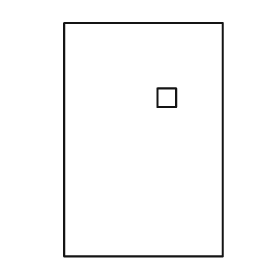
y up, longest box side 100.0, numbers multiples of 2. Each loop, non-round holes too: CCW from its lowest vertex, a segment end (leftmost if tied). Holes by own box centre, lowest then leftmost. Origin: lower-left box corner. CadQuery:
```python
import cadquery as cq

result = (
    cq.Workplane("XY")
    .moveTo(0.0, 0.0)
    .lineTo(68.0, 0.0)
    .lineTo(68.0, 100.0)
    .lineTo(0.0, 100.0)
    .close()
    .moveTo(40.0, 64.0)
    .lineTo(48.0, 64.0)
    .lineTo(48.0, 72.0)
    .lineTo(40.0, 72.0)
    .close()
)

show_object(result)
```